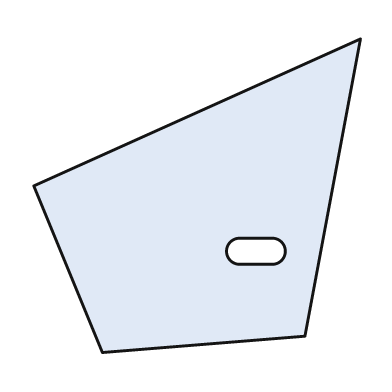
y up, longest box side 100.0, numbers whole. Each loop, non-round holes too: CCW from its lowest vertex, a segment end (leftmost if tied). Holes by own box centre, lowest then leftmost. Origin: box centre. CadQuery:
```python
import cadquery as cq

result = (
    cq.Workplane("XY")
    .moveTo(-29.0, -48.0)
    .lineTo(33.0, -43.0)
    .lineTo(50.0, 48.0)
    .lineTo(-50.0, 3.0)
    .close()
    .moveTo(13.0, -21.0)
    .lineTo(23.0, -21.0)
    .threePointArc((27.0, -17.0), (23.0, -13.0))
    .lineTo(13.0, -13.0)
    .threePointArc((9.0, -17.0), (13.0, -21.0))
    .close()
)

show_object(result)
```